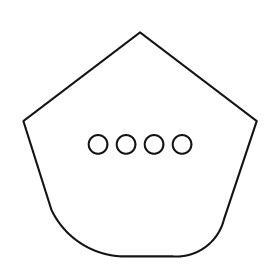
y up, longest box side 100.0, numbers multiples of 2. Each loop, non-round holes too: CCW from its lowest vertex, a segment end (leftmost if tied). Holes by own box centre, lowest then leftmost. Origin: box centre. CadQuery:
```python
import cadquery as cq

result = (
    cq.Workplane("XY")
    .moveTo(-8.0, -48.0)
    .lineTo(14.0, -48.0)
    .threePointArc((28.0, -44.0), (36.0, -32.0))
    .lineTo(50.0, 10.0)
    .lineTo(0.0, 48.0)
    .lineTo(-50.0, 10.0)
    .lineTo(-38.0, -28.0)
    .threePointArc((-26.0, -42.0), (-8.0, -48.0))
    .close()
    .moveTo(-18.0, 0.0)
    .circle(4.0)
    .moveTo(-6.0, 0.0)
    .circle(4.0)
    .moveTo(6.0, 0.0)
    .circle(4.0)
    .moveTo(18.0, 0.0)
    .circle(4.0)
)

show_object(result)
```